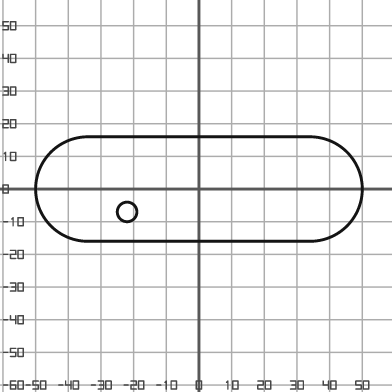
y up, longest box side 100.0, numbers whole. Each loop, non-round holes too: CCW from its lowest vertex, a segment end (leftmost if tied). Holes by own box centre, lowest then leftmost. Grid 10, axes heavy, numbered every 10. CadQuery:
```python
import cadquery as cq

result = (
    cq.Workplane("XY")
    .moveTo(-34.0, -16.0)
    .lineTo(34.0, -16.0)
    .threePointArc((50.0, 0.0), (34.0, 16.0))
    .lineTo(-34.0, 16.0)
    .threePointArc((-50.0, 0.0), (-34.0, -16.0))
    .close()
    .moveTo(-22.0, -7.0)
    .circle(3.0)
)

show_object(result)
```